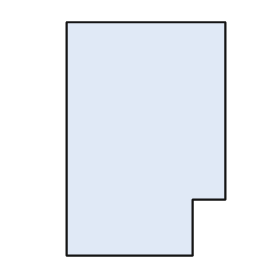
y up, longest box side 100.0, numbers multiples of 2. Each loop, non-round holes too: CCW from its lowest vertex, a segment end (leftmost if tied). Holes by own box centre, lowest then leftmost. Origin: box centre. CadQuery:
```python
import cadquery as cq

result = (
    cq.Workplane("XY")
    .moveTo(-34.0, -50.0)
    .lineTo(20.0, -50.0)
    .lineTo(20.0, -26.0)
    .lineTo(34.0, -26.0)
    .lineTo(34.0, 50.0)
    .lineTo(-34.0, 50.0)
    .close()
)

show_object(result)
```